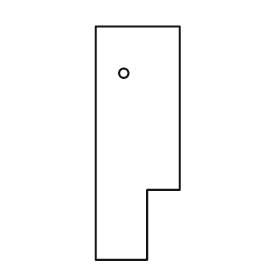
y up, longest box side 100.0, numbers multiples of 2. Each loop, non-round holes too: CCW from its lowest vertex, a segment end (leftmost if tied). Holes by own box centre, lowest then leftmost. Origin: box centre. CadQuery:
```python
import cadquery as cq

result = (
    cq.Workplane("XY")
    .moveTo(-18.0, -50.0)
    .lineTo(4.0, -50.0)
    .lineTo(4.0, -20.0)
    .lineTo(18.0, -20.0)
    .lineTo(18.0, 50.0)
    .lineTo(-18.0, 50.0)
    .close()
    .moveTo(-6.0, 30.0)
    .circle(2.0)
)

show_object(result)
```